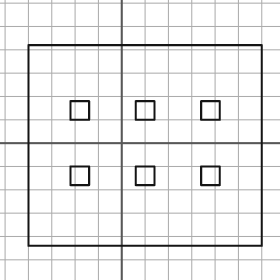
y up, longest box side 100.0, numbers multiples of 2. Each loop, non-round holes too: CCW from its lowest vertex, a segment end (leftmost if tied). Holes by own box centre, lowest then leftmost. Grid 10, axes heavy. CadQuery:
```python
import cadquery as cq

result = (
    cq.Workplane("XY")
    .moveTo(-40.0, -44.0)
    .lineTo(60.0, -44.0)
    .lineTo(60.0, 42.0)
    .lineTo(-40.0, 42.0)
    .close()
    .moveTo(-22.0, -18.0)
    .lineTo(-14.0, -18.0)
    .lineTo(-14.0, -10.0)
    .lineTo(-22.0, -10.0)
    .close()
    .moveTo(6.0, -18.0)
    .lineTo(14.0, -18.0)
    .lineTo(14.0, -10.0)
    .lineTo(6.0, -10.0)
    .close()
    .moveTo(34.0, -18.0)
    .lineTo(42.0, -18.0)
    .lineTo(42.0, -10.0)
    .lineTo(34.0, -10.0)
    .close()
    .moveTo(-22.0, 10.0)
    .lineTo(-14.0, 10.0)
    .lineTo(-14.0, 18.0)
    .lineTo(-22.0, 18.0)
    .close()
    .moveTo(6.0, 10.0)
    .lineTo(14.0, 10.0)
    .lineTo(14.0, 18.0)
    .lineTo(6.0, 18.0)
    .close()
    .moveTo(34.0, 10.0)
    .lineTo(42.0, 10.0)
    .lineTo(42.0, 18.0)
    .lineTo(34.0, 18.0)
    .close()
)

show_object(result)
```